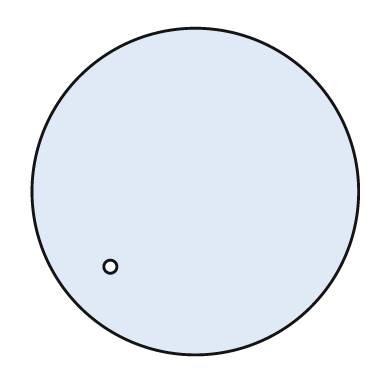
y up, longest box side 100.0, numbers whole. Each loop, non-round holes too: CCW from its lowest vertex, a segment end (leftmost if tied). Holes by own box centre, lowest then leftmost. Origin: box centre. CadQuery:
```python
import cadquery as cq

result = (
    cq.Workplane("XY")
    .moveTo(0.0, 0.0)
    .circle(50.0)
    .moveTo(-26.0, -23.0)
    .circle(2.0)
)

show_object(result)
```